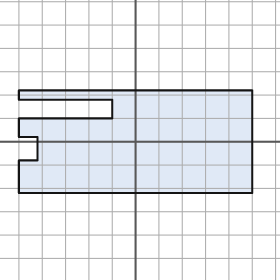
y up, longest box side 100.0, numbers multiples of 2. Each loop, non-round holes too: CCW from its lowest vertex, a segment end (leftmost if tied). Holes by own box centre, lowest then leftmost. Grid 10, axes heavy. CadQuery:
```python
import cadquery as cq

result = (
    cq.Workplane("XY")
    .moveTo(-50.0, -22.0)
    .lineTo(50.0, -22.0)
    .lineTo(50.0, 22.0)
    .lineTo(-50.0, 22.0)
    .lineTo(-50.0, 18.0)
    .lineTo(-10.0, 18.0)
    .lineTo(-10.0, 10.0)
    .lineTo(-50.0, 10.0)
    .lineTo(-50.0, 2.0)
    .lineTo(-42.0, 2.0)
    .lineTo(-42.0, -8.0)
    .lineTo(-50.0, -8.0)
    .close()
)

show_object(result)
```